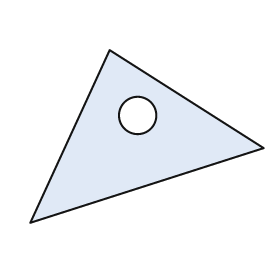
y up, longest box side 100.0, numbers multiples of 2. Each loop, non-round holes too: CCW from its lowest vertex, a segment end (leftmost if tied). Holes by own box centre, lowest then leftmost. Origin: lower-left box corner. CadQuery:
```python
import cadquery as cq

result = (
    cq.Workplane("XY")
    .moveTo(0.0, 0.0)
    .lineTo(100.0, 32.0)
    .lineTo(34.0, 74.0)
    .close()
    .moveTo(46.0, 46.0)
    .circle(8.0)
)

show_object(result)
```